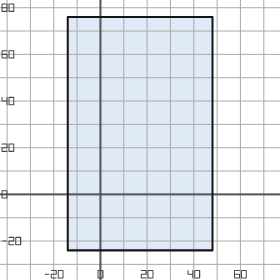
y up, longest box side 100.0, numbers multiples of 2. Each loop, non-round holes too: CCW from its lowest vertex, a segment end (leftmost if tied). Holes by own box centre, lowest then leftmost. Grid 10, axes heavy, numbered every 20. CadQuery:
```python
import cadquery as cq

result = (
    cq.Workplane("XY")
    .moveTo(-14.0, -24.0)
    .lineTo(48.0, -24.0)
    .lineTo(48.0, 76.0)
    .lineTo(-14.0, 76.0)
    .close()
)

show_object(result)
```